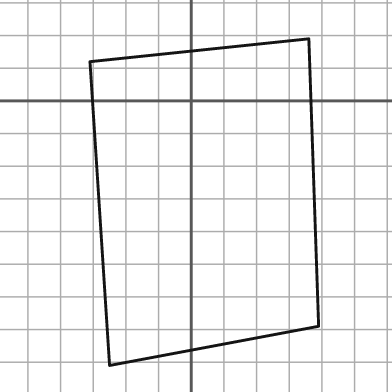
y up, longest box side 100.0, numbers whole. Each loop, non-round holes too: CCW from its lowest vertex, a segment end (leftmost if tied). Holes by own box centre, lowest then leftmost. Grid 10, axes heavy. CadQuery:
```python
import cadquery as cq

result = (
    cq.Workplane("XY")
    .moveTo(-25.0, -81.0)
    .lineTo(39.0, -69.0)
    .lineTo(36.0, 19.0)
    .lineTo(-31.0, 12.0)
    .close()
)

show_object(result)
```